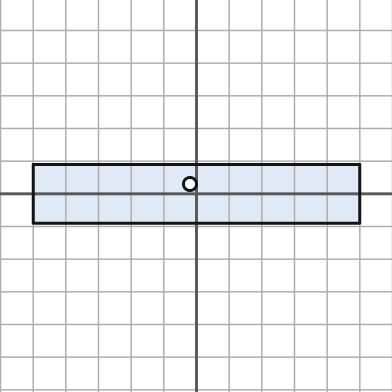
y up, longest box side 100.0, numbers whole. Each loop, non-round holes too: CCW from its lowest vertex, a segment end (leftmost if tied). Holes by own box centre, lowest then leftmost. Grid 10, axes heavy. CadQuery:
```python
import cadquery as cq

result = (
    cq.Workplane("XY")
    .moveTo(-50.0, -9.0)
    .lineTo(50.0, -9.0)
    .lineTo(50.0, 9.0)
    .lineTo(-50.0, 9.0)
    .close()
    .moveTo(-2.0, 3.0)
    .circle(2.0)
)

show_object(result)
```